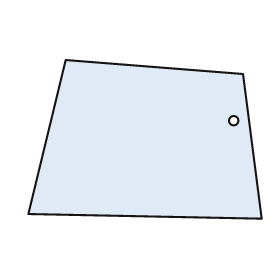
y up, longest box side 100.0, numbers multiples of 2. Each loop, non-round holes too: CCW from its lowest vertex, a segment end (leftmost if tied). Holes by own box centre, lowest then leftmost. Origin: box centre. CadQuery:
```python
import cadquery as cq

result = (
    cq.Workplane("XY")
    .moveTo(50.0, -34.0)
    .lineTo(42.0, 28.0)
    .lineTo(-34.0, 34.0)
    .lineTo(-50.0, -32.0)
    .close()
    .moveTo(38.0, 8.0)
    .circle(2.0)
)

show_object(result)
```